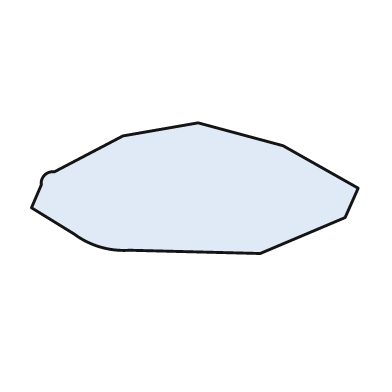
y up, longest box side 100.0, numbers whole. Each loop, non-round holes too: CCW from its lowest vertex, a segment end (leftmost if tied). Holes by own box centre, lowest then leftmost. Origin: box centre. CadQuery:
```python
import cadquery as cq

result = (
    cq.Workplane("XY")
    .moveTo(20.0, -20.0)
    .lineTo(46.0, -9.0)
    .lineTo(50.0, 0.0)
    .lineTo(27.0, 13.0)
    .lineTo(1.0, 20.0)
    .lineTo(-22.0, 16.0)
    .lineTo(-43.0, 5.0)
    .threePointArc((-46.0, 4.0), (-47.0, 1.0))
    .lineTo(-50.0, -6.0)
    .lineTo(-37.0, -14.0)
    .threePointArc((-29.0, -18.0), (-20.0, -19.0))
    .close()
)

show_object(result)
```